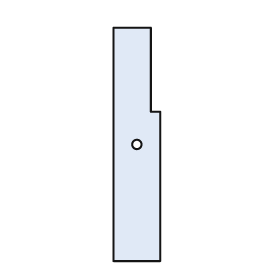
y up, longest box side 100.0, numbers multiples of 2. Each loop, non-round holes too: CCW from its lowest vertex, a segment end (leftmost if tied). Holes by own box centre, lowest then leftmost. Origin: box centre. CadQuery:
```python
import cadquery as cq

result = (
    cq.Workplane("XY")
    .moveTo(-10.0, -50.0)
    .lineTo(10.0, -50.0)
    .lineTo(10.0, 14.0)
    .lineTo(6.0, 14.0)
    .lineTo(6.0, 50.0)
    .lineTo(-10.0, 50.0)
    .close()
    .moveTo(0.0, 0.0)
    .circle(2.0)
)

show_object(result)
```